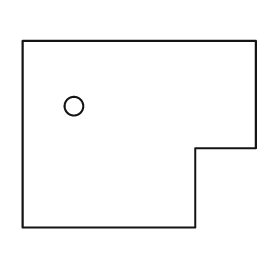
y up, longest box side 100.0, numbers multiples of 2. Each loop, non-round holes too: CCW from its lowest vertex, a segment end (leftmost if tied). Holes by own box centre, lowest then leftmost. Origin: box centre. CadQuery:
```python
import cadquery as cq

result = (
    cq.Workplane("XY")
    .moveTo(-50.0, -40.0)
    .lineTo(24.0, -40.0)
    .lineTo(24.0, -6.0)
    .lineTo(50.0, -6.0)
    .lineTo(50.0, 40.0)
    .lineTo(-50.0, 40.0)
    .close()
    .moveTo(-28.0, 12.0)
    .circle(4.0)
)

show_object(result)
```